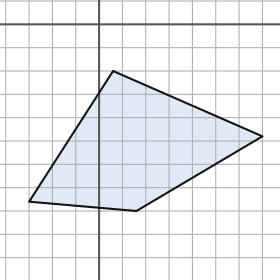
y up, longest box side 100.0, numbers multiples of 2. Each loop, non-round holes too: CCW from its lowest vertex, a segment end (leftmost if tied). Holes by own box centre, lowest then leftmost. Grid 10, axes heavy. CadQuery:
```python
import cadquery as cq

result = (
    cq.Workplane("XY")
    .moveTo(16.0, -80.0)
    .lineTo(70.0, -48.0)
    .lineTo(6.0, -20.0)
    .lineTo(-30.0, -76.0)
    .close()
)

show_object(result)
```